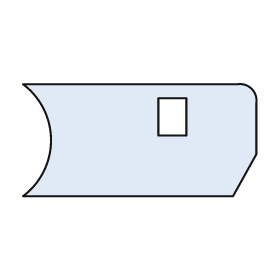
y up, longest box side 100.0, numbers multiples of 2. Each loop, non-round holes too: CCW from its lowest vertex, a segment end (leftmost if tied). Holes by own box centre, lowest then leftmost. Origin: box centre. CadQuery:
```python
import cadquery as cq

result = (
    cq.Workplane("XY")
    .moveTo(-50.0, -24.0)
    .lineTo(40.0, -24.0)
    .lineTo(50.0, -6.0)
    .lineTo(50.0, 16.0)
    .threePointArc((48.0, 22.0), (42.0, 24.0))
    .lineTo(-50.0, 24.0)
    .threePointArc((-38.0, 0.0), (-50.0, -24.0))
    .close()
    .moveTo(8.0, 2.0)
    .lineTo(20.0, 2.0)
    .lineTo(20.0, 18.0)
    .lineTo(8.0, 18.0)
    .close()
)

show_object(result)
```